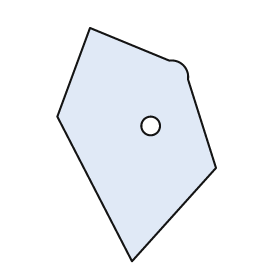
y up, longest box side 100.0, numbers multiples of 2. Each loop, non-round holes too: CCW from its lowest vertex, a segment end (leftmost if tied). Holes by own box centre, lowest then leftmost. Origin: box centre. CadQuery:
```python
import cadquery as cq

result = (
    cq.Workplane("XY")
    .moveTo(-2.0, -50.0)
    .lineTo(34.0, -10.0)
    .lineTo(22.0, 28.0)
    .threePointArc((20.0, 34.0), (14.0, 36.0))
    .lineTo(-20.0, 50.0)
    .lineTo(-34.0, 12.0)
    .close()
    .moveTo(6.0, 8.0)
    .circle(4.0)
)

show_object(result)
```